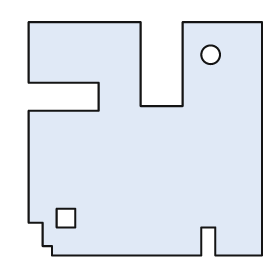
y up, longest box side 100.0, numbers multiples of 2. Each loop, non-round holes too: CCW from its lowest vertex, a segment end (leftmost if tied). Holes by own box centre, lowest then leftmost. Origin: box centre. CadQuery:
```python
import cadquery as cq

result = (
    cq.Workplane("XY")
    .moveTo(-40.0, -50.0)
    .lineTo(24.0, -50.0)
    .lineTo(24.0, -38.0)
    .lineTo(30.0, -38.0)
    .lineTo(30.0, -50.0)
    .lineTo(50.0, -50.0)
    .lineTo(50.0, 50.0)
    .lineTo(16.0, 50.0)
    .lineTo(16.0, 14.0)
    .lineTo(-2.0, 14.0)
    .lineTo(-2.0, 50.0)
    .lineTo(-50.0, 50.0)
    .lineTo(-50.0, 24.0)
    .lineTo(-20.0, 24.0)
    .lineTo(-20.0, 12.0)
    .lineTo(-50.0, 12.0)
    .lineTo(-50.0, -36.0)
    .lineTo(-44.0, -36.0)
    .lineTo(-44.0, -46.0)
    .lineTo(-40.0, -46.0)
    .close()
    .moveTo(-38.0, -38.0)
    .lineTo(-30.0, -38.0)
    .lineTo(-30.0, -30.0)
    .lineTo(-38.0, -30.0)
    .close()
    .moveTo(28.0, 36.0)
    .circle(4.0)
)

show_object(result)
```